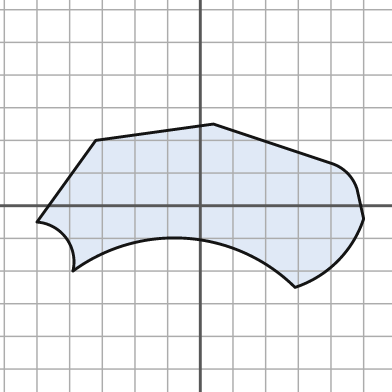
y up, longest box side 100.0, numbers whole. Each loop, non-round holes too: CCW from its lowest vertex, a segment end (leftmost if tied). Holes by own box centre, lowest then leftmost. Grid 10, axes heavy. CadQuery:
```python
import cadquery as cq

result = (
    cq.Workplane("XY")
    .moveTo(29.0, -25.0)
    .threePointArc((42.0, -17.0), (50.0, -4.0))
    .lineTo(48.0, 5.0)
    .threePointArc((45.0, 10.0), (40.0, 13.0))
    .lineTo(4.0, 25.0)
    .lineTo(-32.0, 20.0)
    .lineTo(-50.0, -5.0)
    .threePointArc((-41.0, -10.0), (-39.0, -20.0))
    .threePointArc((-4.0, -10.0), (29.0, -25.0))
    .close()
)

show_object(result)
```